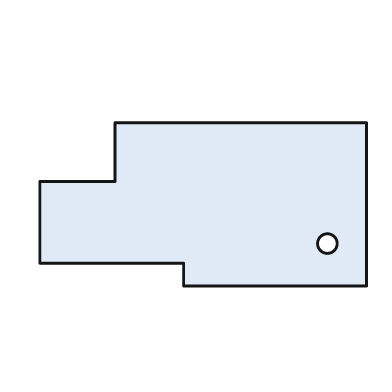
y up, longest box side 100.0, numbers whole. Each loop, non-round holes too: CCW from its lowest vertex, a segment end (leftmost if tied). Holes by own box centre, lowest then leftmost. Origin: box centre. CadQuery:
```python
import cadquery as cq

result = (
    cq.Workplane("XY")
    .moveTo(-6.0, -25.0)
    .lineTo(50.0, -25.0)
    .lineTo(50.0, 25.0)
    .lineTo(-27.0, 25.0)
    .lineTo(-27.0, 7.0)
    .lineTo(-50.0, 7.0)
    .lineTo(-50.0, -18.0)
    .lineTo(-6.0, -18.0)
    .close()
    .moveTo(38.0, -12.0)
    .circle(3.0)
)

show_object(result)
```